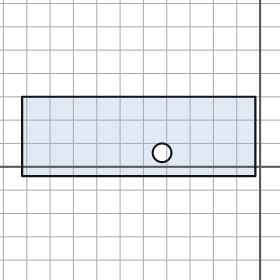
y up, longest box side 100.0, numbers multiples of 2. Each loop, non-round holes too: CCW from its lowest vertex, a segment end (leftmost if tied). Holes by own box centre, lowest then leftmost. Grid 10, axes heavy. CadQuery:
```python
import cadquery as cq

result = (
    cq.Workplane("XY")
    .moveTo(-102.0, -4.0)
    .lineTo(-2.0, -4.0)
    .lineTo(-2.0, 30.0)
    .lineTo(-102.0, 30.0)
    .close()
    .moveTo(-42.0, 6.0)
    .circle(4.0)
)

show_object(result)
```